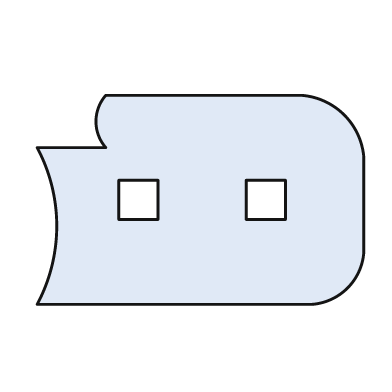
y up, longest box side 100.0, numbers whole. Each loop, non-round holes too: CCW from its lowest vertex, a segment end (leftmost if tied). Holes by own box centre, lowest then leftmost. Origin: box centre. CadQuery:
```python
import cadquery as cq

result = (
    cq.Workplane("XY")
    .moveTo(-50.0, -32.0)
    .lineTo(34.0, -32.0)
    .threePointArc((45.0, -27.0), (50.0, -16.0))
    .lineTo(50.0, 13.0)
    .threePointArc((44.0, 26.0), (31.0, 32.0))
    .lineTo(-29.0, 32.0)
    .threePointArc((-32.0, 24.0), (-29.0, 16.0))
    .lineTo(-50.0, 16.0)
    .threePointArc((-44.0, -8.0), (-50.0, -32.0))
    .close()
    .moveTo(-25.0, -6.0)
    .lineTo(-13.0, -6.0)
    .lineTo(-13.0, 6.0)
    .lineTo(-25.0, 6.0)
    .close()
    .moveTo(14.0, -6.0)
    .lineTo(26.0, -6.0)
    .lineTo(26.0, 6.0)
    .lineTo(14.0, 6.0)
    .close()
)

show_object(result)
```